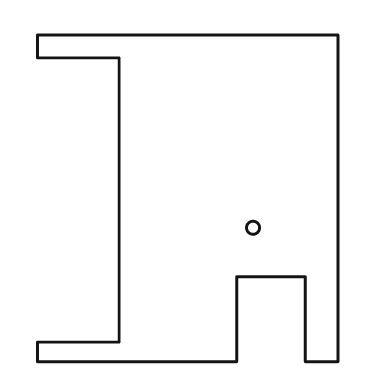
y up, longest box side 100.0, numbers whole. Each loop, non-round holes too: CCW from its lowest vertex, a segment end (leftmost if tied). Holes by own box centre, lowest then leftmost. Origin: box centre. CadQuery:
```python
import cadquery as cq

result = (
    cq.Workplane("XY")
    .moveTo(-46.0, -50.0)
    .lineTo(15.0, -50.0)
    .lineTo(15.0, -24.0)
    .lineTo(36.0, -24.0)
    .lineTo(36.0, -50.0)
    .lineTo(46.0, -50.0)
    .lineTo(46.0, 50.0)
    .lineTo(-46.0, 50.0)
    .lineTo(-46.0, 43.0)
    .lineTo(-21.0, 43.0)
    .lineTo(-21.0, -44.0)
    .lineTo(-46.0, -44.0)
    .close()
    .moveTo(20.0, -9.0)
    .circle(2.0)
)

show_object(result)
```